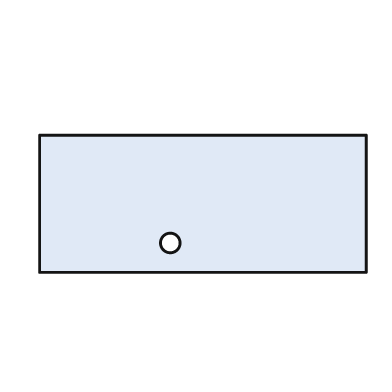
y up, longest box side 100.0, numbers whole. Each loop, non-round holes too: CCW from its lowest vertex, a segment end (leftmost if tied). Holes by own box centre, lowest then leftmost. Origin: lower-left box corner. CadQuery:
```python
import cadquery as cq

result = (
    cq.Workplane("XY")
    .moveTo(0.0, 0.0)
    .lineTo(100.0, 0.0)
    .lineTo(100.0, 42.0)
    .lineTo(0.0, 42.0)
    .close()
    .moveTo(40.0, 9.0)
    .circle(3.0)
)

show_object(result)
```